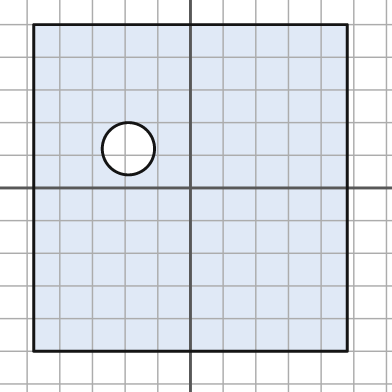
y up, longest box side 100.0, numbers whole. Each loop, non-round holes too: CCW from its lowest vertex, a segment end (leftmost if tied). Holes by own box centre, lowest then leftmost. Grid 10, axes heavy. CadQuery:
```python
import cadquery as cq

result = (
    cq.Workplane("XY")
    .moveTo(-48.0, -50.0)
    .lineTo(48.0, -50.0)
    .lineTo(48.0, 50.0)
    .lineTo(-48.0, 50.0)
    .close()
    .moveTo(-19.0, 12.0)
    .circle(8.0)
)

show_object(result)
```